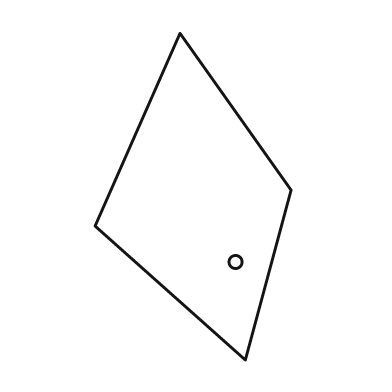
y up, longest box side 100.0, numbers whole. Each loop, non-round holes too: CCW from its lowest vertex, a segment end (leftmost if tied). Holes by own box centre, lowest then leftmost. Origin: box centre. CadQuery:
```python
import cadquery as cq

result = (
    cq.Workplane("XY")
    .moveTo(16.0, -50.0)
    .lineTo(30.0, 2.0)
    .lineTo(-4.0, 50.0)
    .lineTo(-30.0, -9.0)
    .close()
    .moveTo(13.0, -20.0)
    .circle(2.0)
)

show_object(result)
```